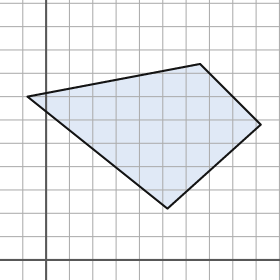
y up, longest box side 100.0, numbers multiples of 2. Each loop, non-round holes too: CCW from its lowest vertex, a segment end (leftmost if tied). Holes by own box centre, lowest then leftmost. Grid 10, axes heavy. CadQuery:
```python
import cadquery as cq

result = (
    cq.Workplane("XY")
    .moveTo(52.0, 22.0)
    .lineTo(92.0, 58.0)
    .lineTo(66.0, 84.0)
    .lineTo(-8.0, 70.0)
    .close()
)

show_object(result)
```